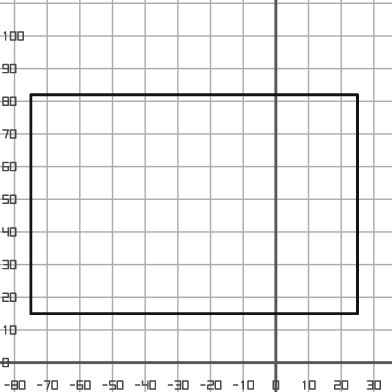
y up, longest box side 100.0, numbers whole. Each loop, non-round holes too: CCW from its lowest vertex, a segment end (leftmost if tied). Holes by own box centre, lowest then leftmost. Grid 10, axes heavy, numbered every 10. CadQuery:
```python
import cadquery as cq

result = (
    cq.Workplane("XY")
    .moveTo(-75.0, 15.0)
    .lineTo(25.0, 15.0)
    .lineTo(25.0, 82.0)
    .lineTo(-75.0, 82.0)
    .close()
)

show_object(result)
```